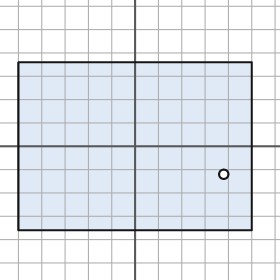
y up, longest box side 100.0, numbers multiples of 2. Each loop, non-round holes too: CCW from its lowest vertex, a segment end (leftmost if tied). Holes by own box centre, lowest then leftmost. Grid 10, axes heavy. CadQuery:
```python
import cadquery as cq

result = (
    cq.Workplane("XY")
    .moveTo(-50.0, -36.0)
    .lineTo(50.0, -36.0)
    .lineTo(50.0, 36.0)
    .lineTo(-50.0, 36.0)
    .close()
    .moveTo(38.0, -12.0)
    .circle(2.0)
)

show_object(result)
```